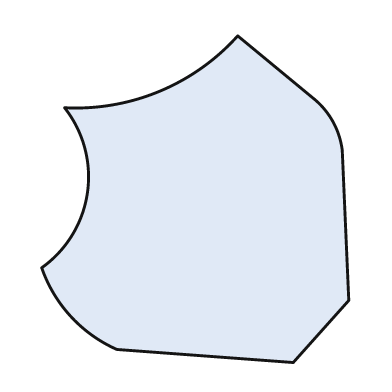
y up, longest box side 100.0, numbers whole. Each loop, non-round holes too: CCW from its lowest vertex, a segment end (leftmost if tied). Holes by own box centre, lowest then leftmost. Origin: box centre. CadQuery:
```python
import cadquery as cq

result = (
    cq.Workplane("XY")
    .moveTo(30.0, -50.0)
    .lineTo(47.0, -31.0)
    .lineTo(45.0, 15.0)
    .threePointArc((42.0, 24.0), (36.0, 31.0))
    .lineTo(13.0, 50.0)
    .threePointArc((-11.0, 33.0), (-40.0, 28.0))
    .threePointArc((-33.0, 2.0), (-47.0, -21.0))
    .threePointArc((-38.0, -36.0), (-24.0, -46.0))
    .close()
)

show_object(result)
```